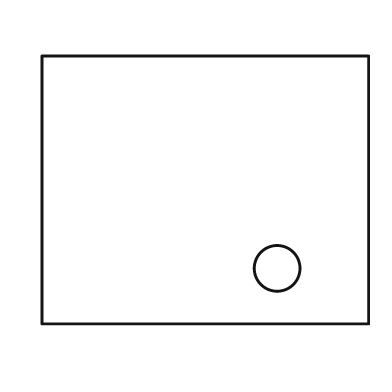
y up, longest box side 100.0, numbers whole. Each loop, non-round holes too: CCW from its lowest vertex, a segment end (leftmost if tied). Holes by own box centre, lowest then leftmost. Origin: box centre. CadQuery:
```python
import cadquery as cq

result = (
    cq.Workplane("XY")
    .moveTo(-50.0, -41.0)
    .lineTo(50.0, -41.0)
    .lineTo(50.0, 41.0)
    .lineTo(-50.0, 41.0)
    .close()
    .moveTo(22.0, -24.0)
    .circle(7.0)
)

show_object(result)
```